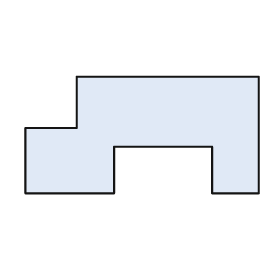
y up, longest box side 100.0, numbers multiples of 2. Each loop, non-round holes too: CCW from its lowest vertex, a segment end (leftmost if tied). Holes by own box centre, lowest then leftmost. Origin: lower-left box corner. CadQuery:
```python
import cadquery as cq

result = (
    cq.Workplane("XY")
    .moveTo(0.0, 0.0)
    .lineTo(38.0, 0.0)
    .lineTo(38.0, 20.0)
    .lineTo(80.0, 20.0)
    .lineTo(80.0, 0.0)
    .lineTo(100.0, 0.0)
    .lineTo(100.0, 50.0)
    .lineTo(22.0, 50.0)
    .lineTo(22.0, 28.0)
    .lineTo(0.0, 28.0)
    .close()
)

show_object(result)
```